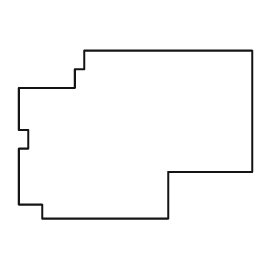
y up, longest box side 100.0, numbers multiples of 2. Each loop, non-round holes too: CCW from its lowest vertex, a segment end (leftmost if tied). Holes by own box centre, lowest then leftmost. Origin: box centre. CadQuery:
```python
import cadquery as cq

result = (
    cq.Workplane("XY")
    .moveTo(-40.0, -36.0)
    .lineTo(14.0, -36.0)
    .lineTo(14.0, -16.0)
    .lineTo(50.0, -16.0)
    .lineTo(50.0, 36.0)
    .lineTo(-22.0, 36.0)
    .lineTo(-22.0, 28.0)
    .lineTo(-26.0, 28.0)
    .lineTo(-26.0, 20.0)
    .lineTo(-50.0, 20.0)
    .lineTo(-50.0, 2.0)
    .lineTo(-46.0, 2.0)
    .lineTo(-46.0, -6.0)
    .lineTo(-50.0, -6.0)
    .lineTo(-50.0, -30.0)
    .lineTo(-40.0, -30.0)
    .close()
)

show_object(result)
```